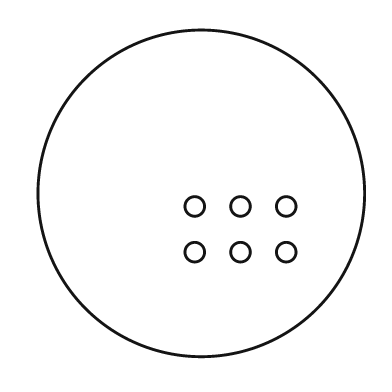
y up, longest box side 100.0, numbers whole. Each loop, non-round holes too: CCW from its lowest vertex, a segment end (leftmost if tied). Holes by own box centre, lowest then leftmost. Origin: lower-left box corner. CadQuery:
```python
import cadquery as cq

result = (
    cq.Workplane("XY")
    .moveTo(50.0, 50.0)
    .circle(50.0)
    .moveTo(48.0, 32.0)
    .circle(3.0)
    .moveTo(62.0, 32.0)
    .circle(3.0)
    .moveTo(76.0, 32.0)
    .circle(3.0)
    .moveTo(48.0, 46.0)
    .circle(3.0)
    .moveTo(62.0, 46.0)
    .circle(3.0)
    .moveTo(76.0, 46.0)
    .circle(3.0)
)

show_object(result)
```